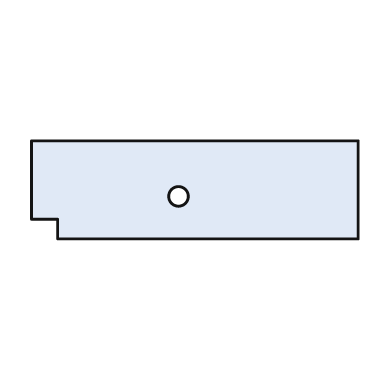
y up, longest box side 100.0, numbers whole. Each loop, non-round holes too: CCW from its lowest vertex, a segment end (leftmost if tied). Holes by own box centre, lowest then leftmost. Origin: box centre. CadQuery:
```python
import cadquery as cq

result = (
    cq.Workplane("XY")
    .moveTo(-42.0, -15.0)
    .lineTo(50.0, -15.0)
    .lineTo(50.0, 15.0)
    .lineTo(-50.0, 15.0)
    .lineTo(-50.0, -9.0)
    .lineTo(-42.0, -9.0)
    .close()
    .moveTo(-5.0, -2.0)
    .circle(3.0)
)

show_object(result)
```